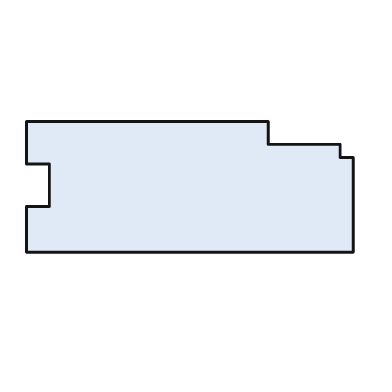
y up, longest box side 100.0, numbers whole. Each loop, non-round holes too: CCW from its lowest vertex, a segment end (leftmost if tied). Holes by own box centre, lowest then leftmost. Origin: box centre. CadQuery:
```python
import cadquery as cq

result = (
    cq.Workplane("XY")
    .moveTo(-50.0, -20.0)
    .lineTo(50.0, -20.0)
    .lineTo(50.0, 9.0)
    .lineTo(46.0, 9.0)
    .lineTo(46.0, 13.0)
    .lineTo(24.0, 13.0)
    .lineTo(24.0, 20.0)
    .lineTo(-50.0, 20.0)
    .lineTo(-50.0, 7.0)
    .lineTo(-43.0, 7.0)
    .lineTo(-43.0, -6.0)
    .lineTo(-50.0, -6.0)
    .close()
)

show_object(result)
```